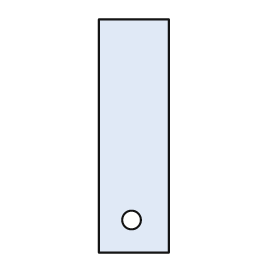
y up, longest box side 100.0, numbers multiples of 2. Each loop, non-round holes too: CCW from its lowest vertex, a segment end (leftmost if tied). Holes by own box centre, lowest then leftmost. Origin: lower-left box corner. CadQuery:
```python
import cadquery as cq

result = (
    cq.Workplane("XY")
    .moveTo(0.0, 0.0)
    .lineTo(30.0, 0.0)
    .lineTo(30.0, 100.0)
    .lineTo(0.0, 100.0)
    .close()
    .moveTo(14.0, 14.0)
    .circle(4.0)
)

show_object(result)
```